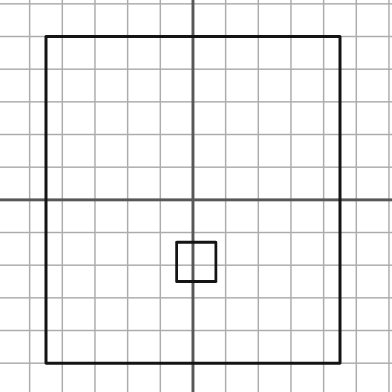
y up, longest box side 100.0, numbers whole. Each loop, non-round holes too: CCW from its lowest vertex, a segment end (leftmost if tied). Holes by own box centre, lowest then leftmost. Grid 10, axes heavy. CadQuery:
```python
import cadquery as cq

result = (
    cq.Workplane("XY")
    .moveTo(-45.0, -50.0)
    .lineTo(45.0, -50.0)
    .lineTo(45.0, 50.0)
    .lineTo(-45.0, 50.0)
    .close()
    .moveTo(-5.0, -25.0)
    .lineTo(7.0, -25.0)
    .lineTo(7.0, -13.0)
    .lineTo(-5.0, -13.0)
    .close()
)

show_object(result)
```